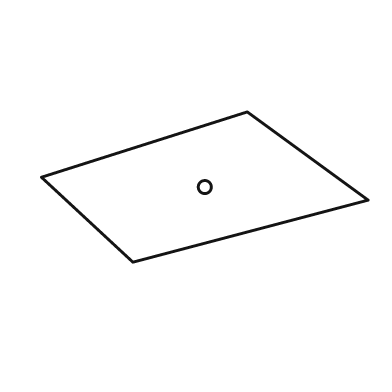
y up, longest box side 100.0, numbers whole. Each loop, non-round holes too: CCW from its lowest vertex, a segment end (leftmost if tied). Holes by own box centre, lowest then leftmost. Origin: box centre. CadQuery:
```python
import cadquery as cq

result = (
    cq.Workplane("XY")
    .moveTo(-22.0, -23.0)
    .lineTo(50.0, -4.0)
    .lineTo(13.0, 23.0)
    .lineTo(-50.0, 3.0)
    .close()
    .moveTo(0.0, 0.0)
    .circle(2.0)
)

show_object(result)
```